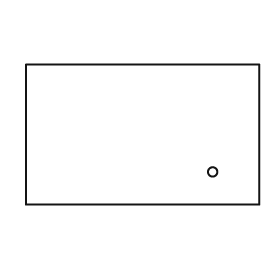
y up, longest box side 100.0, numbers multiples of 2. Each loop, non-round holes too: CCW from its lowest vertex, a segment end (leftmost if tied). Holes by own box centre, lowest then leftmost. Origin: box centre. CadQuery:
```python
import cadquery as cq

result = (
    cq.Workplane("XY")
    .moveTo(-50.0, -30.0)
    .lineTo(50.0, -30.0)
    .lineTo(50.0, 30.0)
    .lineTo(-50.0, 30.0)
    .close()
    .moveTo(30.0, -16.0)
    .circle(2.0)
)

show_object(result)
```